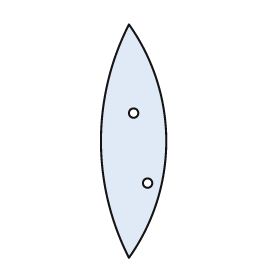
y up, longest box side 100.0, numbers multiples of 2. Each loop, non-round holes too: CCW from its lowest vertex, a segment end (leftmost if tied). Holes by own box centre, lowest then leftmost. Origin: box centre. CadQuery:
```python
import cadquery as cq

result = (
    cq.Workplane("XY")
    .moveTo(-2.0, -50.0)
    .threePointArc((14.0, 0.0), (-2.0, 50.0))
    .threePointArc((-14.0, 0.0), (-2.0, -50.0))
    .close()
    .moveTo(6.0, -18.0)
    .circle(2.0)
    .moveTo(0.0, 12.0)
    .circle(2.0)
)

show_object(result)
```